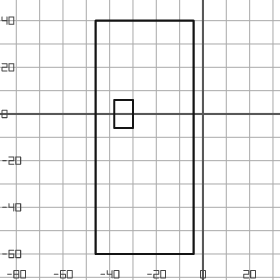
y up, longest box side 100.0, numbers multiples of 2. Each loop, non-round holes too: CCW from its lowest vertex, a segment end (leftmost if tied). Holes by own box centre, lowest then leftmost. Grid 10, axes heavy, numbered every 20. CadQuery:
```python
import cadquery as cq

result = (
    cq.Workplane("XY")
    .moveTo(-46.0, -60.0)
    .lineTo(-4.0, -60.0)
    .lineTo(-4.0, 40.0)
    .lineTo(-46.0, 40.0)
    .close()
    .moveTo(-38.0, -6.0)
    .lineTo(-30.0, -6.0)
    .lineTo(-30.0, 6.0)
    .lineTo(-38.0, 6.0)
    .close()
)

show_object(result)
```